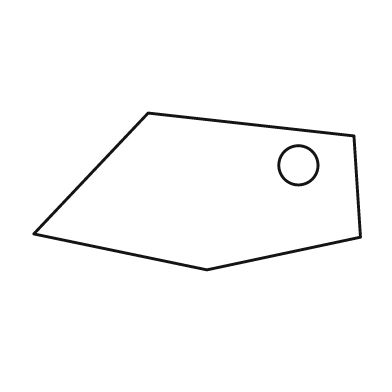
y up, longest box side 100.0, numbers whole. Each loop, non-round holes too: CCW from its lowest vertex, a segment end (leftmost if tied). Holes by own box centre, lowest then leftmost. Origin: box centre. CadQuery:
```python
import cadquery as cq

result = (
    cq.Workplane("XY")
    .moveTo(3.0, -24.0)
    .lineTo(50.0, -14.0)
    .lineTo(48.0, 17.0)
    .lineTo(-15.0, 24.0)
    .lineTo(-50.0, -13.0)
    .close()
    .moveTo(31.0, 8.0)
    .circle(6.0)
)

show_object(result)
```